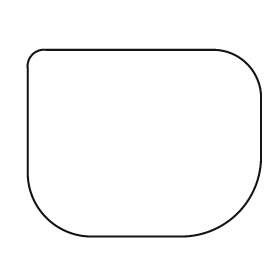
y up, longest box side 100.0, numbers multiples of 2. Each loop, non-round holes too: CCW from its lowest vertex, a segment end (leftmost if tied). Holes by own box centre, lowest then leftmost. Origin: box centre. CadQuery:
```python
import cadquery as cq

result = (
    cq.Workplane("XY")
    .moveTo(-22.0, -40.0)
    .lineTo(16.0, -40.0)
    .threePointArc((40.0, -30.0), (50.0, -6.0))
    .lineTo(50.0, 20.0)
    .threePointArc((44.0, 34.0), (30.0, 40.0))
    .lineTo(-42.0, 40.0)
    .threePointArc((-48.0, 38.0), (-50.0, 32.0))
    .lineTo(-50.0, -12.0)
    .threePointArc((-42.0, -32.0), (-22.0, -40.0))
    .close()
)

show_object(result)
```